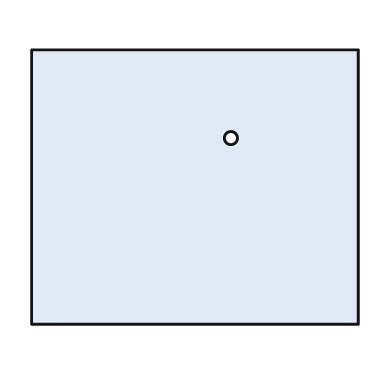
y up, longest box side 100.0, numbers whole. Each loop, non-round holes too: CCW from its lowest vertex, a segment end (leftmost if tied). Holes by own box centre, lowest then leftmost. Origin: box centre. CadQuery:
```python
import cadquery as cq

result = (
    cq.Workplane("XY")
    .moveTo(-50.0, -42.0)
    .lineTo(50.0, -42.0)
    .lineTo(50.0, 42.0)
    .lineTo(-50.0, 42.0)
    .close()
    .moveTo(11.0, 15.0)
    .circle(2.0)
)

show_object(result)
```